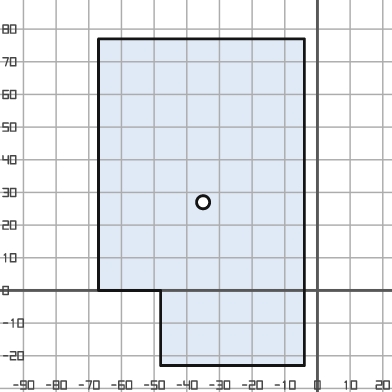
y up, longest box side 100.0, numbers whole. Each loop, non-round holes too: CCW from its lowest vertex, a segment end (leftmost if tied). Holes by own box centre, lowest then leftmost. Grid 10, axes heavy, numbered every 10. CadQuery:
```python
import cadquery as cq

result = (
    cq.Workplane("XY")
    .moveTo(-48.0, -23.0)
    .lineTo(-4.0, -23.0)
    .lineTo(-4.0, 77.0)
    .lineTo(-67.0, 77.0)
    .lineTo(-67.0, 0.0)
    .lineTo(-48.0, 0.0)
    .close()
    .moveTo(-35.0, 27.0)
    .circle(2.0)
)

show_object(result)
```